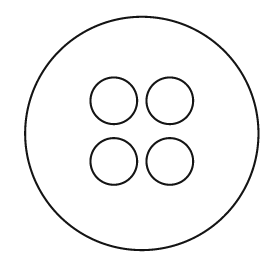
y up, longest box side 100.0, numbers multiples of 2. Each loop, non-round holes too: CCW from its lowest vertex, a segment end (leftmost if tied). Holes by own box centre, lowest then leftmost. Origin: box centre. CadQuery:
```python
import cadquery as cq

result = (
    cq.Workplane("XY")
    .moveTo(0.0, 0.0)
    .circle(50.0)
    .moveTo(-12.0, -12.0)
    .circle(10.0)
    .moveTo(12.0, -12.0)
    .circle(10.0)
    .moveTo(-12.0, 14.0)
    .circle(10.0)
    .moveTo(12.0, 14.0)
    .circle(10.0)
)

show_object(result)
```